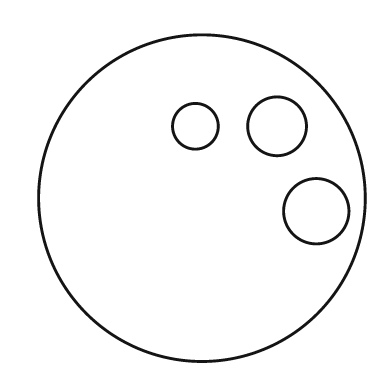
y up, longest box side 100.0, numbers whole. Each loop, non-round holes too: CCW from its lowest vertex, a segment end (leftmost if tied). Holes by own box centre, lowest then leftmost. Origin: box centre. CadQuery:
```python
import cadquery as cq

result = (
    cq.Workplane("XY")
    .moveTo(0.0, 0.0)
    .circle(50.0)
    .moveTo(35.0, -4.0)
    .circle(10.0)
    .moveTo(-2.0, 22.0)
    .circle(7.0)
    .moveTo(23.0, 22.0)
    .circle(9.0)
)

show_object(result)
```